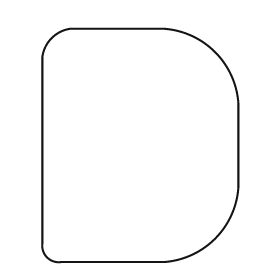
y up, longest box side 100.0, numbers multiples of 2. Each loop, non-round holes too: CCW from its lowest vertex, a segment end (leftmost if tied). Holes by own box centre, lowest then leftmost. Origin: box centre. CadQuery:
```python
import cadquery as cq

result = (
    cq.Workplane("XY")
    .moveTo(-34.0, -50.0)
    .lineTo(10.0, -50.0)
    .threePointArc((32.0, -40.0), (42.0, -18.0))
    .lineTo(42.0, 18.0)
    .threePointArc((32.0, 40.0), (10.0, 50.0))
    .lineTo(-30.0, 50.0)
    .threePointArc((-38.0, 46.0), (-42.0, 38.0))
    .lineTo(-42.0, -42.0)
    .threePointArc((-40.0, -48.0), (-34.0, -50.0))
    .close()
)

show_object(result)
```